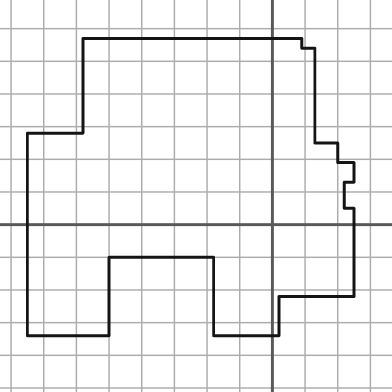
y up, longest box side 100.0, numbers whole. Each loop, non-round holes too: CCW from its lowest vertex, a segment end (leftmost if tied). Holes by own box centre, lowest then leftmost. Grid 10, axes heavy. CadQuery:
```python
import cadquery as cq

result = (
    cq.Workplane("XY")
    .moveTo(-75.0, -34.0)
    .lineTo(-50.0, -34.0)
    .lineTo(-50.0, -10.0)
    .lineTo(-18.0, -10.0)
    .lineTo(-18.0, -34.0)
    .lineTo(2.0, -34.0)
    .lineTo(2.0, -22.0)
    .lineTo(25.0, -22.0)
    .lineTo(25.0, 5.0)
    .lineTo(22.0, 5.0)
    .lineTo(22.0, 13.0)
    .lineTo(25.0, 13.0)
    .lineTo(25.0, 19.0)
    .lineTo(20.0, 19.0)
    .lineTo(20.0, 25.0)
    .lineTo(13.0, 25.0)
    .lineTo(13.0, 54.0)
    .lineTo(9.0, 54.0)
    .lineTo(9.0, 57.0)
    .lineTo(-58.0, 57.0)
    .lineTo(-58.0, 28.0)
    .lineTo(-75.0, 28.0)
    .close()
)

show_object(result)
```